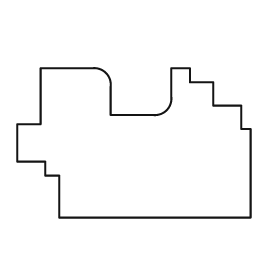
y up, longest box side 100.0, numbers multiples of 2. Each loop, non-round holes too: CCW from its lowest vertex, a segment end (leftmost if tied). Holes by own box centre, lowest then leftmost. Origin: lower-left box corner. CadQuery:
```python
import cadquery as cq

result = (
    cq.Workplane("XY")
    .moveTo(18.0, 0.0)
    .lineTo(100.0, 0.0)
    .lineTo(100.0, 38.0)
    .lineTo(96.0, 38.0)
    .lineTo(96.0, 48.0)
    .lineTo(84.0, 48.0)
    .lineTo(84.0, 58.0)
    .lineTo(74.0, 58.0)
    .lineTo(74.0, 64.0)
    .lineTo(66.0, 64.0)
    .lineTo(66.0, 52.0)
    .threePointArc((64.0, 46.0), (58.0, 44.0))
    .lineTo(40.0, 44.0)
    .lineTo(40.0, 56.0)
    .threePointArc((38.0, 62.0), (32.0, 64.0))
    .lineTo(10.0, 64.0)
    .lineTo(10.0, 40.0)
    .lineTo(0.0, 40.0)
    .lineTo(0.0, 24.0)
    .lineTo(12.0, 24.0)
    .lineTo(12.0, 18.0)
    .lineTo(18.0, 18.0)
    .close()
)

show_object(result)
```